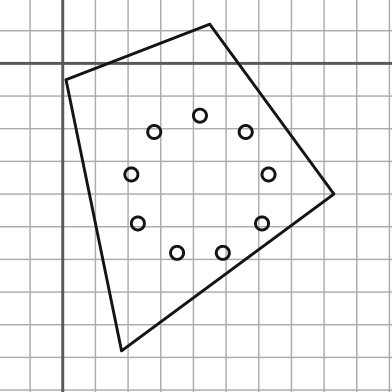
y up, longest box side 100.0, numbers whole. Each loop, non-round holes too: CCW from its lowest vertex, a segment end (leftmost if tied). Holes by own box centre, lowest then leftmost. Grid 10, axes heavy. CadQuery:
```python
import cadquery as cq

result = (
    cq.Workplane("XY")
    .moveTo(18.0, -88.0)
    .lineTo(83.0, -40.0)
    .lineTo(45.0, 12.0)
    .lineTo(1.0, -5.0)
    .close()
    .moveTo(35.0, -58.0)
    .circle(2.0)
    .moveTo(49.0, -58.0)
    .circle(2.0)
    .moveTo(23.0, -49.0)
    .circle(2.0)
    .moveTo(61.0, -49.0)
    .circle(2.0)
    .moveTo(21.0, -34.0)
    .circle(2.0)
    .moveTo(63.0, -34.0)
    .circle(2.0)
    .moveTo(28.0, -21.0)
    .circle(2.0)
    .moveTo(56.0, -21.0)
    .circle(2.0)
    .moveTo(42.0, -16.0)
    .circle(2.0)
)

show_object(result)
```